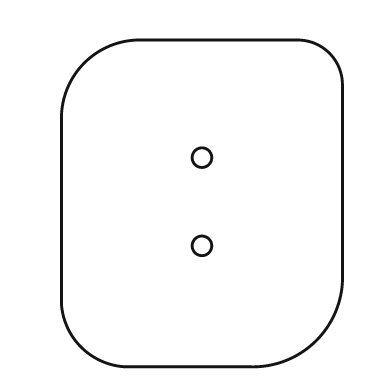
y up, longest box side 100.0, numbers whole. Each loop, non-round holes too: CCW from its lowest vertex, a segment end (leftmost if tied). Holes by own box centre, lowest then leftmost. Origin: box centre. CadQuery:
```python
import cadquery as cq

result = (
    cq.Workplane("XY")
    .moveTo(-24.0, -50.0)
    .lineTo(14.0, -50.0)
    .threePointArc((35.0, -42.0), (43.0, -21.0))
    .lineTo(43.0, 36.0)
    .threePointArc((39.0, 46.0), (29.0, 50.0))
    .lineTo(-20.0, 50.0)
    .threePointArc((-36.0, 43.0), (-43.0, 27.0))
    .lineTo(-43.0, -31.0)
    .threePointArc((-37.0, -44.0), (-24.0, -50.0))
    .close()
    .moveTo(0.0, -13.0)
    .circle(3.0)
    .moveTo(0.0, 14.0)
    .circle(3.0)
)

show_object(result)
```